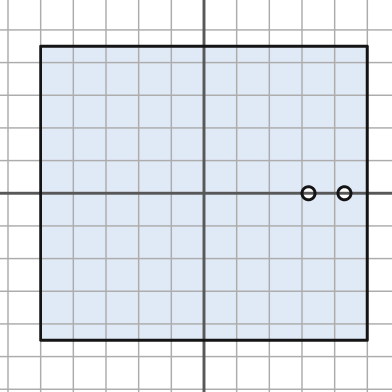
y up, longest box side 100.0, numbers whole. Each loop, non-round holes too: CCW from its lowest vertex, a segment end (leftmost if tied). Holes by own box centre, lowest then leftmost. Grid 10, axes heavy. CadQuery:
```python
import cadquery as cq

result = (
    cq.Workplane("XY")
    .moveTo(-50.0, -45.0)
    .lineTo(50.0, -45.0)
    .lineTo(50.0, 45.0)
    .lineTo(-50.0, 45.0)
    .close()
    .moveTo(32.0, 0.0)
    .circle(2.0)
    .moveTo(43.0, 0.0)
    .circle(2.0)
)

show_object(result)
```